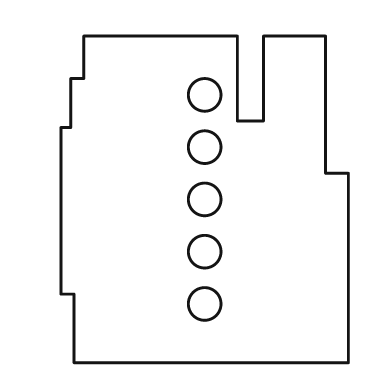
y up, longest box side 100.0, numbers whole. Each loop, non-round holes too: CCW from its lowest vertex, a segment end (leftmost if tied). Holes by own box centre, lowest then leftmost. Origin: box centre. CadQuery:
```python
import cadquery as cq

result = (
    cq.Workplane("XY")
    .moveTo(-40.0, -50.0)
    .lineTo(44.0, -50.0)
    .lineTo(44.0, 8.0)
    .lineTo(37.0, 8.0)
    .lineTo(37.0, 50.0)
    .lineTo(18.0, 50.0)
    .lineTo(18.0, 24.0)
    .lineTo(10.0, 24.0)
    .lineTo(10.0, 50.0)
    .lineTo(-37.0, 50.0)
    .lineTo(-37.0, 37.0)
    .lineTo(-41.0, 37.0)
    .lineTo(-41.0, 22.0)
    .lineTo(-44.0, 22.0)
    .lineTo(-44.0, -29.0)
    .lineTo(-40.0, -29.0)
    .close()
    .moveTo(0.0, -32.0)
    .circle(5.0)
    .moveTo(0.0, -16.0)
    .circle(5.0)
    .moveTo(0.0, 0.0)
    .circle(5.0)
    .moveTo(0.0, 16.0)
    .circle(5.0)
    .moveTo(0.0, 32.0)
    .circle(5.0)
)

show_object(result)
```